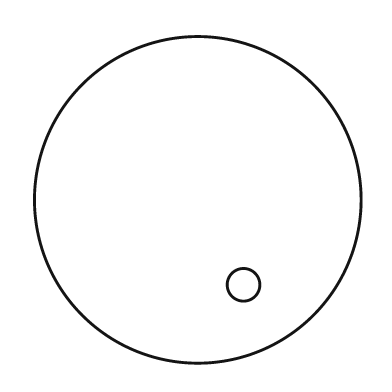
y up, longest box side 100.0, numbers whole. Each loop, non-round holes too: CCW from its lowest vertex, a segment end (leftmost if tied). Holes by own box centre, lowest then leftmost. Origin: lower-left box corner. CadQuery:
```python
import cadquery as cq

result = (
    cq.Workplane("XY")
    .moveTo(50.0, 50.0)
    .circle(50.0)
    .moveTo(64.0, 24.0)
    .circle(5.0)
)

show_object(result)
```